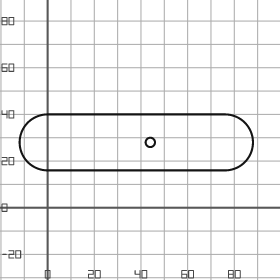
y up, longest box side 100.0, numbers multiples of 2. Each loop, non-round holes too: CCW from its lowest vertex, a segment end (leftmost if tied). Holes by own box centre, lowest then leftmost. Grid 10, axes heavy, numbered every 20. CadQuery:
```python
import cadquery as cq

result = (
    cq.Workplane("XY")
    .moveTo(0.0, 16.0)
    .lineTo(76.0, 16.0)
    .threePointArc((88.0, 28.0), (76.0, 40.0))
    .lineTo(0.0, 40.0)
    .threePointArc((-12.0, 28.0), (0.0, 16.0))
    .close()
    .moveTo(44.0, 28.0)
    .circle(2.0)
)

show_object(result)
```